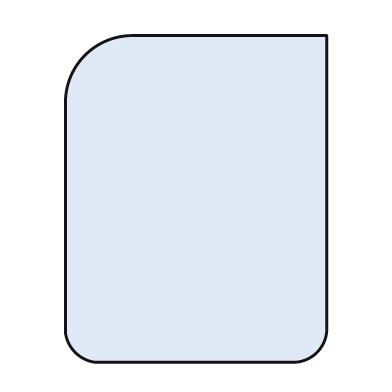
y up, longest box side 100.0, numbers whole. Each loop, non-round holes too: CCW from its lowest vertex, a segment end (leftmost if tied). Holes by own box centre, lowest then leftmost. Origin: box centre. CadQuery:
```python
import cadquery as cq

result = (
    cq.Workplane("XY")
    .moveTo(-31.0, -50.0)
    .lineTo(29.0, -50.0)
    .threePointArc((37.0, -47.0), (40.0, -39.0))
    .lineTo(40.0, 50.0)
    .lineTo(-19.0, 50.0)
    .threePointArc((-34.0, 44.0), (-40.0, 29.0))
    .lineTo(-40.0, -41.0)
    .threePointArc((-37.0, -47.0), (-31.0, -50.0))
    .close()
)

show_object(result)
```